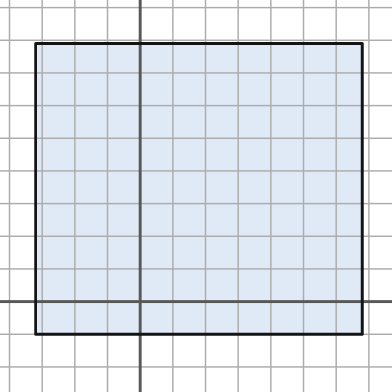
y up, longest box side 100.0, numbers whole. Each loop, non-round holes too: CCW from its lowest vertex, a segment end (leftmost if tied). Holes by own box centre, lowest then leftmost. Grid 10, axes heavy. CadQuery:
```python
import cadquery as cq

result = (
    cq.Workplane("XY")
    .moveTo(-32.0, -10.0)
    .lineTo(68.0, -10.0)
    .lineTo(68.0, 79.0)
    .lineTo(-32.0, 79.0)
    .close()
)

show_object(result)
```